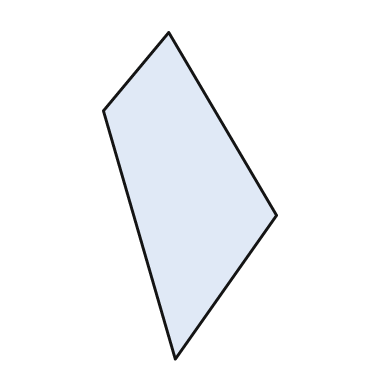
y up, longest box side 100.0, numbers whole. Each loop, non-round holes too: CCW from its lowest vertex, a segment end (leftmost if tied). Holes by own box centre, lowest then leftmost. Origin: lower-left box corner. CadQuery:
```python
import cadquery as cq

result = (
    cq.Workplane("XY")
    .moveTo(22.0, 0.0)
    .lineTo(53.0, 44.0)
    .lineTo(20.0, 100.0)
    .lineTo(0.0, 76.0)
    .close()
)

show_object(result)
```